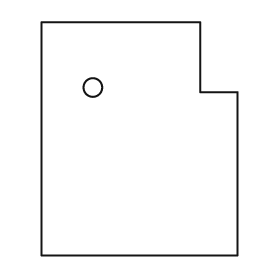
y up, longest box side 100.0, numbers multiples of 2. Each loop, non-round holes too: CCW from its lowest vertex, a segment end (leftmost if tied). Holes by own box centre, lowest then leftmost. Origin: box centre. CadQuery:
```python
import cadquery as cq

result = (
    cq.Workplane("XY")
    .moveTo(-42.0, -50.0)
    .lineTo(42.0, -50.0)
    .lineTo(42.0, 20.0)
    .lineTo(26.0, 20.0)
    .lineTo(26.0, 50.0)
    .lineTo(-42.0, 50.0)
    .close()
    .moveTo(-20.0, 22.0)
    .circle(4.0)
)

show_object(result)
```